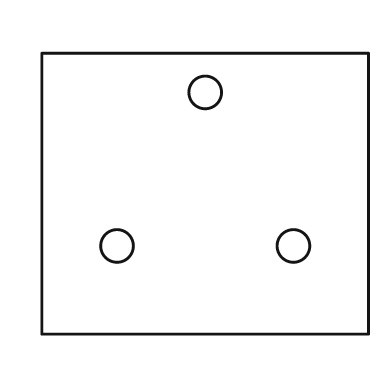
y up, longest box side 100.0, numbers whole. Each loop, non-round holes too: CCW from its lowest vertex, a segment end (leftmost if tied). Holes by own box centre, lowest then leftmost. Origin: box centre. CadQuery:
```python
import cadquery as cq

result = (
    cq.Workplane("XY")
    .moveTo(-50.0, -43.0)
    .lineTo(50.0, -43.0)
    .lineTo(50.0, 43.0)
    .lineTo(-50.0, 43.0)
    .close()
    .moveTo(-27.0, -16.0)
    .circle(5.0)
    .moveTo(27.0, -16.0)
    .circle(5.0)
    .moveTo(0.0, 31.0)
    .circle(5.0)
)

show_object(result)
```